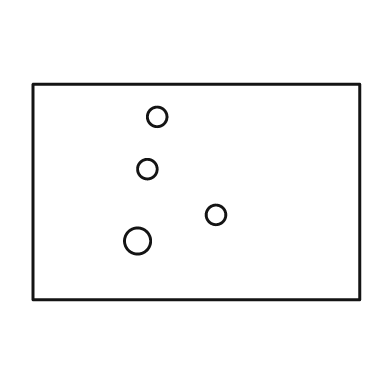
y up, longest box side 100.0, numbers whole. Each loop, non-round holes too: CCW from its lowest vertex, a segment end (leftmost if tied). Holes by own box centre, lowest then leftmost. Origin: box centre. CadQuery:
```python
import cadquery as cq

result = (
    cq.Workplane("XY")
    .moveTo(-50.0, -33.0)
    .lineTo(50.0, -33.0)
    .lineTo(50.0, 33.0)
    .lineTo(-50.0, 33.0)
    .close()
    .moveTo(-18.0, -15.0)
    .circle(4.0)
    .moveTo(6.0, -7.0)
    .circle(3.0)
    .moveTo(-15.0, 7.0)
    .circle(3.0)
    .moveTo(-12.0, 23.0)
    .circle(3.0)
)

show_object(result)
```